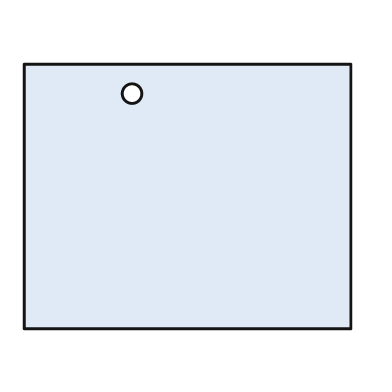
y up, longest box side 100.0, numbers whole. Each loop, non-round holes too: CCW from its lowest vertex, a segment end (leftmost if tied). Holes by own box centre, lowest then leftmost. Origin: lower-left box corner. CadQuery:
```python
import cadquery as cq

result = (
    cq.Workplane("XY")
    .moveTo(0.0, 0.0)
    .lineTo(100.0, 0.0)
    .lineTo(100.0, 81.0)
    .lineTo(0.0, 81.0)
    .close()
    .moveTo(33.0, 72.0)
    .circle(3.0)
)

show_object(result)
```